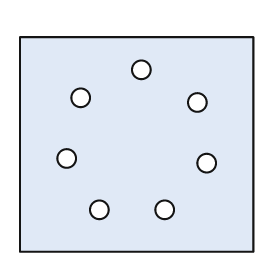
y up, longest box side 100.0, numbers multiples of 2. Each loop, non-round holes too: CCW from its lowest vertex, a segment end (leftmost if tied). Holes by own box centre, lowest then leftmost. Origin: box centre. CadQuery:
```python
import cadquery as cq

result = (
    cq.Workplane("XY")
    .moveTo(-50.0, -46.0)
    .lineTo(50.0, -46.0)
    .lineTo(50.0, 46.0)
    .lineTo(-50.0, 46.0)
    .close()
    .moveTo(-16.0, -28.0)
    .circle(4.0)
    .moveTo(12.0, -28.0)
    .circle(4.0)
    .moveTo(30.0, -8.0)
    .circle(4.0)
    .moveTo(-30.0, -6.0)
    .circle(4.0)
    .moveTo(26.0, 18.0)
    .circle(4.0)
    .moveTo(-24.0, 20.0)
    .circle(4.0)
    .moveTo(2.0, 32.0)
    .circle(4.0)
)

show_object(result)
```